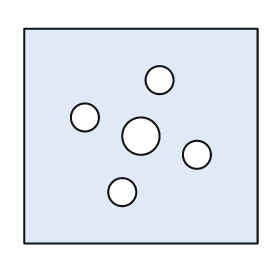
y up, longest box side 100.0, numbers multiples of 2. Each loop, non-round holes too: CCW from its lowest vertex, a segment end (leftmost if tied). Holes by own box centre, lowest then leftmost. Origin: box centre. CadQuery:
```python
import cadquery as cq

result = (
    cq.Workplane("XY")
    .moveTo(-50.0, -46.0)
    .lineTo(50.0, -46.0)
    .lineTo(50.0, 46.0)
    .lineTo(-50.0, 46.0)
    .close()
    .moveTo(-8.0, -24.0)
    .circle(6.0)
    .moveTo(24.0, -8.0)
    .circle(6.0)
    .moveTo(0.0, 0.0)
    .circle(8.0)
    .moveTo(-24.0, 8.0)
    .circle(6.0)
    .moveTo(8.0, 24.0)
    .circle(6.0)
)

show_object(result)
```